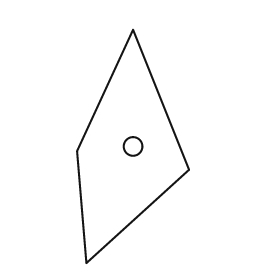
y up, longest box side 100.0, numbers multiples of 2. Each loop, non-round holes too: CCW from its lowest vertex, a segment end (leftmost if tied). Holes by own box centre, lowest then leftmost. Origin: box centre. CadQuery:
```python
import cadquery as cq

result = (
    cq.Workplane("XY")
    .moveTo(-20.0, -50.0)
    .lineTo(24.0, -10.0)
    .lineTo(0.0, 50.0)
    .lineTo(-24.0, -2.0)
    .close()
    .moveTo(0.0, 0.0)
    .circle(4.0)
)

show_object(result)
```